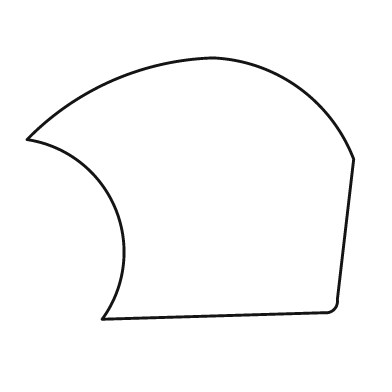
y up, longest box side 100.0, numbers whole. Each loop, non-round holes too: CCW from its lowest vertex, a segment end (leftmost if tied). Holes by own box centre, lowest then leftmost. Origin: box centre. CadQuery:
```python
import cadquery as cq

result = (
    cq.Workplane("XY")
    .moveTo(-27.0, -40.0)
    .lineTo(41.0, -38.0)
    .threePointArc((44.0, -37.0), (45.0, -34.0))
    .lineTo(50.0, 9.0)
    .threePointArc((33.0, 31.0), (7.0, 40.0))
    .threePointArc((-24.0, 33.0), (-50.0, 15.0))
    .threePointArc((-23.0, -6.0), (-27.0, -40.0))
    .close()
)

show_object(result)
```